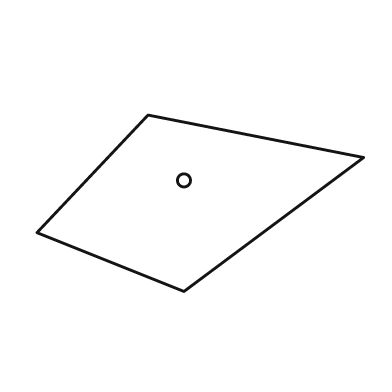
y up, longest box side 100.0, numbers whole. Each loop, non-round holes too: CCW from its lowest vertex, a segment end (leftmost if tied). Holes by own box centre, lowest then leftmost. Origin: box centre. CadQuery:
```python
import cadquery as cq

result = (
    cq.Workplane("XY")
    .moveTo(-5.0, -27.0)
    .lineTo(50.0, 14.0)
    .lineTo(-16.0, 27.0)
    .lineTo(-50.0, -9.0)
    .close()
    .moveTo(-5.0, 7.0)
    .circle(2.0)
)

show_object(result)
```